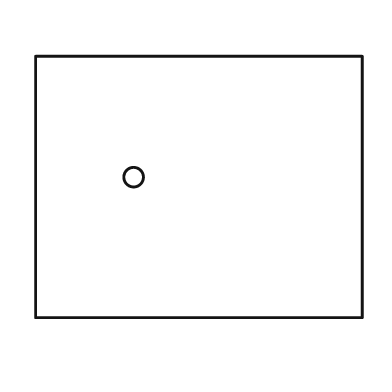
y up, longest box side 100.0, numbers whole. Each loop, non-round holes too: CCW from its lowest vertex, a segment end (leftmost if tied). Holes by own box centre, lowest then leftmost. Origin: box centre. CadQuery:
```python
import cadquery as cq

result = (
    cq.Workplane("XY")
    .moveTo(-50.0, -40.0)
    .lineTo(50.0, -40.0)
    .lineTo(50.0, 40.0)
    .lineTo(-50.0, 40.0)
    .close()
    .moveTo(-20.0, 3.0)
    .circle(3.0)
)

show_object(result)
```